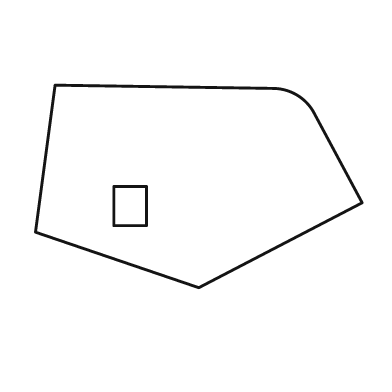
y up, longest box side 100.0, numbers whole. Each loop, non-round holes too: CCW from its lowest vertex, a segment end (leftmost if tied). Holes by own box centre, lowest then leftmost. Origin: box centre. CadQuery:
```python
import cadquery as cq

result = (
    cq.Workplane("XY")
    .moveTo(0.0, -31.0)
    .lineTo(50.0, -5.0)
    .lineTo(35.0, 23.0)
    .threePointArc((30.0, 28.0), (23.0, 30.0))
    .lineTo(-44.0, 31.0)
    .lineTo(-50.0, -14.0)
    .close()
    .moveTo(-26.0, -12.0)
    .lineTo(-16.0, -12.0)
    .lineTo(-16.0, 0.0)
    .lineTo(-26.0, 0.0)
    .close()
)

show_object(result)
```